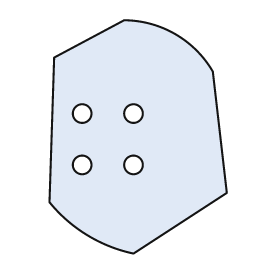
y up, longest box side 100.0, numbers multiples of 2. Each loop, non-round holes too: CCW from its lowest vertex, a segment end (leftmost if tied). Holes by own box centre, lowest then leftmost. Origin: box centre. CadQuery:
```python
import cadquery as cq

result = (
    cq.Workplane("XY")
    .moveTo(-2.0, -50.0)
    .lineTo(38.0, -24.0)
    .lineTo(32.0, 28.0)
    .threePointArc((16.0, 44.0), (-6.0, 50.0))
    .lineTo(-36.0, 34.0)
    .lineTo(-38.0, -28.0)
    .threePointArc((-22.0, -42.0), (-2.0, -50.0))
    .close()
    .moveTo(-24.0, -12.0)
    .circle(4.0)
    .moveTo(-2.0, -12.0)
    .circle(4.0)
    .moveTo(-24.0, 10.0)
    .circle(4.0)
    .moveTo(-2.0, 10.0)
    .circle(4.0)
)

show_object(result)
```